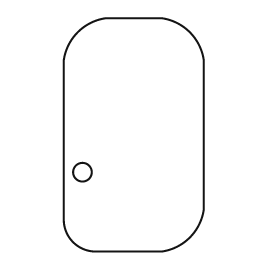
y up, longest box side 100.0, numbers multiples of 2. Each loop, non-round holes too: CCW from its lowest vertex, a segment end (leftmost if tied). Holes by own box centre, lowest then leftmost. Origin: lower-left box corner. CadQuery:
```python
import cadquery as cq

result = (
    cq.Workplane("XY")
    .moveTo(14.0, 0.0)
    .lineTo(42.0, 0.0)
    .threePointArc((54.0, 6.0), (60.0, 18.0))
    .lineTo(60.0, 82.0)
    .threePointArc((54.0, 94.0), (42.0, 100.0))
    .lineTo(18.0, 100.0)
    .threePointArc((6.0, 94.0), (0.0, 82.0))
    .lineTo(0.0, 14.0)
    .threePointArc((4.0, 4.0), (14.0, 0.0))
    .close()
    .moveTo(8.0, 34.0)
    .circle(4.0)
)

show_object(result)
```